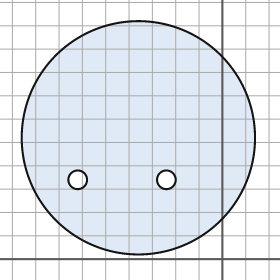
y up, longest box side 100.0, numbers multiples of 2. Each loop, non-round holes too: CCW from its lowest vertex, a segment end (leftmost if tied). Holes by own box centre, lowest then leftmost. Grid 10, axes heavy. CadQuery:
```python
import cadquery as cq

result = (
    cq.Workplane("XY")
    .moveTo(-36.0, 52.0)
    .circle(50.0)
    .moveTo(-62.0, 34.0)
    .circle(4.0)
    .moveTo(-24.0, 34.0)
    .circle(4.0)
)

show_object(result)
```